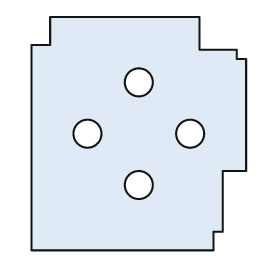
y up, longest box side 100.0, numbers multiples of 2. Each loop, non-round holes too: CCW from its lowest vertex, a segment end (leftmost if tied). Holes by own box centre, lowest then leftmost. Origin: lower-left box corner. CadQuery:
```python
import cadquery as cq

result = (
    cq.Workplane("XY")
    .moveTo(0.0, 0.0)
    .lineTo(78.0, 0.0)
    .lineTo(78.0, 8.0)
    .lineTo(82.0, 8.0)
    .lineTo(82.0, 34.0)
    .lineTo(92.0, 34.0)
    .lineTo(92.0, 82.0)
    .lineTo(88.0, 82.0)
    .lineTo(88.0, 86.0)
    .lineTo(72.0, 86.0)
    .lineTo(72.0, 100.0)
    .lineTo(8.0, 100.0)
    .lineTo(8.0, 88.0)
    .lineTo(0.0, 88.0)
    .close()
    .moveTo(46.0, 28.0)
    .circle(6.0)
    .moveTo(24.0, 50.0)
    .circle(6.0)
    .moveTo(68.0, 50.0)
    .circle(6.0)
    .moveTo(46.0, 72.0)
    .circle(6.0)
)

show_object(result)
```